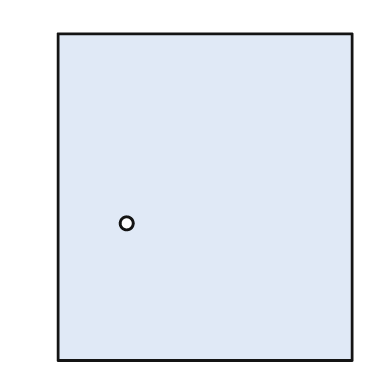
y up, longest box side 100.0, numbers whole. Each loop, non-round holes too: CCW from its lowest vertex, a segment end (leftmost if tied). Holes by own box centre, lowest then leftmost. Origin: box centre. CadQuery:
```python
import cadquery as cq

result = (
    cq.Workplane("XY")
    .moveTo(-45.0, -50.0)
    .lineTo(45.0, -50.0)
    .lineTo(45.0, 50.0)
    .lineTo(-45.0, 50.0)
    .close()
    .moveTo(-24.0, -8.0)
    .circle(2.0)
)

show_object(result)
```